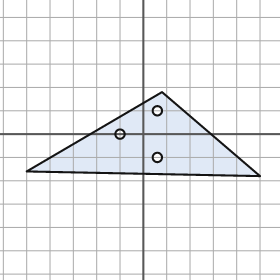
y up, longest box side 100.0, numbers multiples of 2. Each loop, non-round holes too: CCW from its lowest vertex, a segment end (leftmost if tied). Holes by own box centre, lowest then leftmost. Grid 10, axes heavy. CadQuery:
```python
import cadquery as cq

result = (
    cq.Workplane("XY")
    .moveTo(50.0, -18.0)
    .lineTo(8.0, 18.0)
    .lineTo(-50.0, -16.0)
    .close()
    .moveTo(6.0, -10.0)
    .circle(2.0)
    .moveTo(-10.0, 0.0)
    .circle(2.0)
    .moveTo(6.0, 10.0)
    .circle(2.0)
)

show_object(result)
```